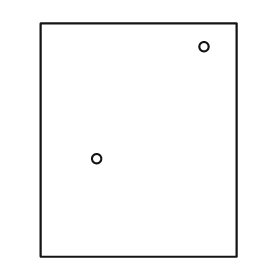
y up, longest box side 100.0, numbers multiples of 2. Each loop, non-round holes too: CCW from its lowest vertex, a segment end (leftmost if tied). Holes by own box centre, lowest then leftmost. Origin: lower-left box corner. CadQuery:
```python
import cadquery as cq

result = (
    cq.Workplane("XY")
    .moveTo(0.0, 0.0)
    .lineTo(84.0, 0.0)
    .lineTo(84.0, 100.0)
    .lineTo(0.0, 100.0)
    .close()
    .moveTo(24.0, 42.0)
    .circle(2.0)
    .moveTo(70.0, 90.0)
    .circle(2.0)
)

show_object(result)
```